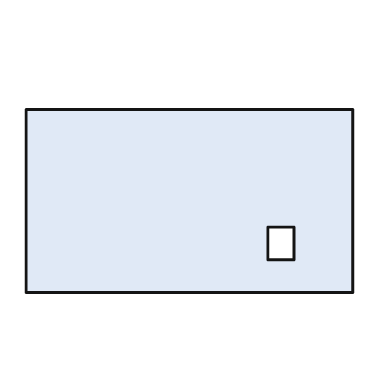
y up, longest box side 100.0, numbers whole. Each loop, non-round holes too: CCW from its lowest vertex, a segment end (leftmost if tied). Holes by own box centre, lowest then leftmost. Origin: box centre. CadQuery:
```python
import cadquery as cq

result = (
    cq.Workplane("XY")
    .moveTo(-50.0, -28.0)
    .lineTo(50.0, -28.0)
    .lineTo(50.0, 28.0)
    .lineTo(-50.0, 28.0)
    .close()
    .moveTo(24.0, -18.0)
    .lineTo(32.0, -18.0)
    .lineTo(32.0, -8.0)
    .lineTo(24.0, -8.0)
    .close()
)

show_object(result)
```